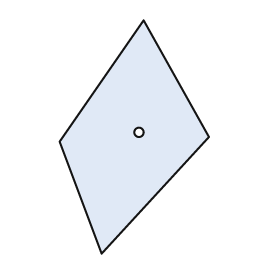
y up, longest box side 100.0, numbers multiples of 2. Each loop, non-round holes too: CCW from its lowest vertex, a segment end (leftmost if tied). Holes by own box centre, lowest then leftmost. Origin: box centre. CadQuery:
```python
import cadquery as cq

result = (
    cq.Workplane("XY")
    .moveTo(-14.0, -50.0)
    .lineTo(32.0, 0.0)
    .lineTo(4.0, 50.0)
    .lineTo(-32.0, -2.0)
    .close()
    .moveTo(2.0, 2.0)
    .circle(2.0)
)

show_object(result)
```